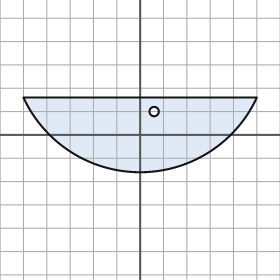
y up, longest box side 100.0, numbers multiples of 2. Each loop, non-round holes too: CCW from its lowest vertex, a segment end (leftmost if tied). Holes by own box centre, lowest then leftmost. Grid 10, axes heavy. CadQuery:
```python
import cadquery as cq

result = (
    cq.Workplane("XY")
    .moveTo(-50.0, 16.0)
    .threePointArc((0.0, -16.0), (50.0, 16.0))
    .close()
    .moveTo(6.0, 10.0)
    .circle(2.0)
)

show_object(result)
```